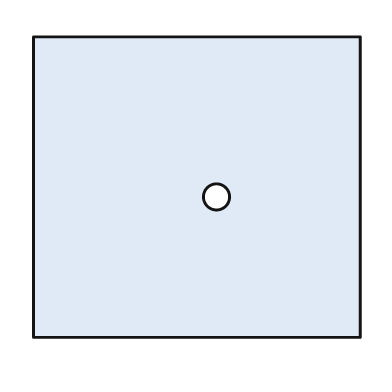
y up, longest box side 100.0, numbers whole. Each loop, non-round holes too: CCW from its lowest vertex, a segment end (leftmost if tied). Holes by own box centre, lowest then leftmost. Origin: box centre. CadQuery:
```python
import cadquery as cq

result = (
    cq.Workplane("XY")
    .moveTo(-50.0, -46.0)
    .lineTo(50.0, -46.0)
    .lineTo(50.0, 46.0)
    .lineTo(-50.0, 46.0)
    .close()
    .moveTo(6.0, -3.0)
    .circle(4.0)
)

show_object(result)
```